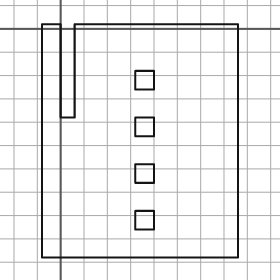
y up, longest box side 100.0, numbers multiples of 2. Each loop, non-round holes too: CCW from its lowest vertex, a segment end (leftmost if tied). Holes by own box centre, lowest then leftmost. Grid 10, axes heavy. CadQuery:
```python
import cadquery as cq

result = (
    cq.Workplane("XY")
    .moveTo(-8.0, -98.0)
    .lineTo(76.0, -98.0)
    .lineTo(76.0, 2.0)
    .lineTo(6.0, 2.0)
    .lineTo(6.0, -38.0)
    .lineTo(0.0, -38.0)
    .lineTo(0.0, 2.0)
    .lineTo(-8.0, 2.0)
    .close()
    .moveTo(32.0, -86.0)
    .lineTo(40.0, -86.0)
    .lineTo(40.0, -78.0)
    .lineTo(32.0, -78.0)
    .close()
    .moveTo(32.0, -66.0)
    .lineTo(40.0, -66.0)
    .lineTo(40.0, -58.0)
    .lineTo(32.0, -58.0)
    .close()
    .moveTo(32.0, -46.0)
    .lineTo(40.0, -46.0)
    .lineTo(40.0, -38.0)
    .lineTo(32.0, -38.0)
    .close()
    .moveTo(32.0, -26.0)
    .lineTo(40.0, -26.0)
    .lineTo(40.0, -18.0)
    .lineTo(32.0, -18.0)
    .close()
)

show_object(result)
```